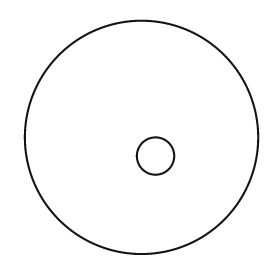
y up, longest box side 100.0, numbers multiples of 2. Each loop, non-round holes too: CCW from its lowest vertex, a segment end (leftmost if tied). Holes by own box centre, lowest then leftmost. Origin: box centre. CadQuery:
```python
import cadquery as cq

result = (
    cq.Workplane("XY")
    .moveTo(0.0, 0.0)
    .circle(50.0)
    .moveTo(6.0, -8.0)
    .circle(8.0)
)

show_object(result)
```